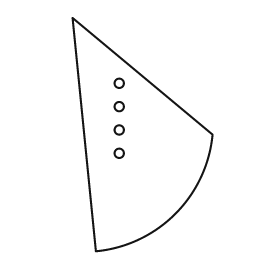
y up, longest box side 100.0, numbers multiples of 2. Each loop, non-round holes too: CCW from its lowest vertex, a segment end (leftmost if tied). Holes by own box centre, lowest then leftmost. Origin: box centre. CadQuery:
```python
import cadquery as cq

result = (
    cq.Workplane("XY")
    .moveTo(-20.0, -50.0)
    .threePointArc((14.0, -34.0), (30.0, 0.0))
    .lineTo(-30.0, 50.0)
    .close()
    .moveTo(-10.0, -8.0)
    .circle(2.0)
    .moveTo(-10.0, 2.0)
    .circle(2.0)
    .moveTo(-10.0, 12.0)
    .circle(2.0)
    .moveTo(-10.0, 22.0)
    .circle(2.0)
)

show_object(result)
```